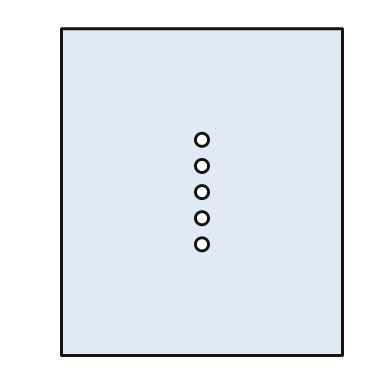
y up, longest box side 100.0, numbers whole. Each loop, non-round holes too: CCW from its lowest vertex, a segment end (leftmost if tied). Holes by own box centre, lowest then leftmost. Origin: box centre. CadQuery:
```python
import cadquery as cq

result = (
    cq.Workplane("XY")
    .moveTo(-43.0, -50.0)
    .lineTo(43.0, -50.0)
    .lineTo(43.0, 50.0)
    .lineTo(-43.0, 50.0)
    .close()
    .moveTo(0.0, -16.0)
    .circle(2.0)
    .moveTo(0.0, -8.0)
    .circle(2.0)
    .moveTo(0.0, 0.0)
    .circle(2.0)
    .moveTo(0.0, 8.0)
    .circle(2.0)
    .moveTo(0.0, 16.0)
    .circle(2.0)
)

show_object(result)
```